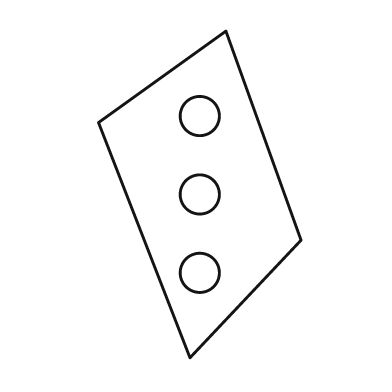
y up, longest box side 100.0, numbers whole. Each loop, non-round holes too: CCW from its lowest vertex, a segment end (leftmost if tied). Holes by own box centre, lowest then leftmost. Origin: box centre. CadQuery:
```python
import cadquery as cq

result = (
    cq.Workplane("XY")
    .moveTo(-3.0, -50.0)
    .lineTo(31.0, -14.0)
    .lineTo(8.0, 50.0)
    .lineTo(-31.0, 22.0)
    .close()
    .moveTo(0.0, -24.0)
    .circle(6.0)
    .moveTo(0.0, 0.0)
    .circle(6.0)
    .moveTo(0.0, 24.0)
    .circle(6.0)
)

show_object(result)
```